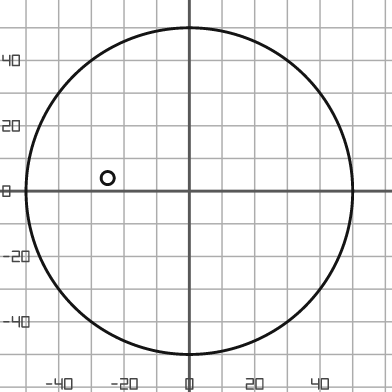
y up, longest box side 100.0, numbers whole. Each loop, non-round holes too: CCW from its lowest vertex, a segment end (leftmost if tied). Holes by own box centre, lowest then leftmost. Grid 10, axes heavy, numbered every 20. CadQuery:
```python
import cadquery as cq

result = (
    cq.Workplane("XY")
    .moveTo(0.0, 0.0)
    .circle(50.0)
    .moveTo(-25.0, 4.0)
    .circle(2.0)
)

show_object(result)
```